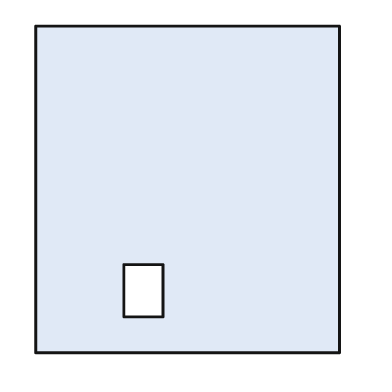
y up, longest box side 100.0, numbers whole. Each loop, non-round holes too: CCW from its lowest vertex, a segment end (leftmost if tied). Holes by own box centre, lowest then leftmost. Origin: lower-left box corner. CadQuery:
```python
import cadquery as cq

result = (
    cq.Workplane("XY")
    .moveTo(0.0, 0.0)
    .lineTo(93.0, 0.0)
    .lineTo(93.0, 100.0)
    .lineTo(0.0, 100.0)
    .close()
    .moveTo(27.0, 11.0)
    .lineTo(39.0, 11.0)
    .lineTo(39.0, 27.0)
    .lineTo(27.0, 27.0)
    .close()
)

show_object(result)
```